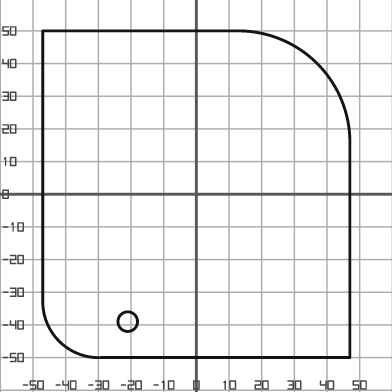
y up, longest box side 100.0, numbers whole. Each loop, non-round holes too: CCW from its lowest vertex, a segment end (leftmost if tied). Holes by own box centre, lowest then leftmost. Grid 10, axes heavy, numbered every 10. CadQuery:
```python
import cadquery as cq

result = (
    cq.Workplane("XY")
    .moveTo(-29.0, -50.0)
    .lineTo(47.0, -50.0)
    .lineTo(47.0, 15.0)
    .threePointArc((37.0, 40.0), (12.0, 50.0))
    .lineTo(-47.0, 50.0)
    .lineTo(-47.0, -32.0)
    .threePointArc((-42.0, -45.0), (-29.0, -50.0))
    .close()
    .moveTo(-21.0, -39.0)
    .circle(3.0)
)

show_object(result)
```